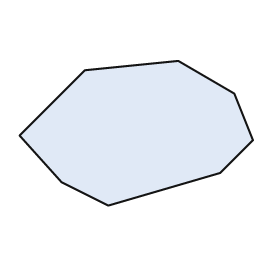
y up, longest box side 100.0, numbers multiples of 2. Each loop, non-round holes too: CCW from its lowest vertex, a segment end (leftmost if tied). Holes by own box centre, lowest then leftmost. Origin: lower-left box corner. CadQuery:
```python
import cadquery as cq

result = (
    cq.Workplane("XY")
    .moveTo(38.0, 0.0)
    .lineTo(86.0, 14.0)
    .lineTo(100.0, 28.0)
    .lineTo(92.0, 48.0)
    .lineTo(68.0, 62.0)
    .lineTo(28.0, 58.0)
    .lineTo(0.0, 30.0)
    .lineTo(18.0, 10.0)
    .close()
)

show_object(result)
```